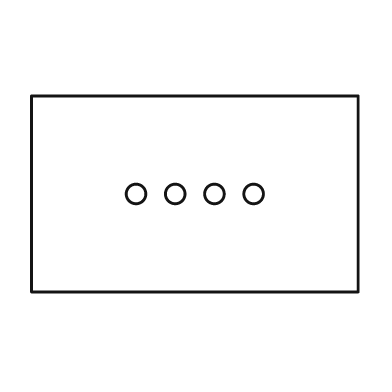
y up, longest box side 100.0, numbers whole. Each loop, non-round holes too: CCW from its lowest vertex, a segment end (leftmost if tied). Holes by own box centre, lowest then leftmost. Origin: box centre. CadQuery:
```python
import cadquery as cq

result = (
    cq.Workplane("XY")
    .moveTo(-50.0, -30.0)
    .lineTo(50.0, -30.0)
    .lineTo(50.0, 30.0)
    .lineTo(-50.0, 30.0)
    .close()
    .moveTo(-18.0, 0.0)
    .circle(3.0)
    .moveTo(-6.0, 0.0)
    .circle(3.0)
    .moveTo(6.0, 0.0)
    .circle(3.0)
    .moveTo(18.0, 0.0)
    .circle(3.0)
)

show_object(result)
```